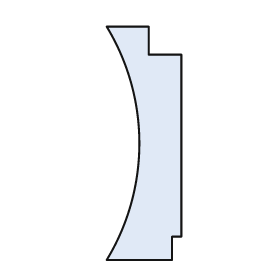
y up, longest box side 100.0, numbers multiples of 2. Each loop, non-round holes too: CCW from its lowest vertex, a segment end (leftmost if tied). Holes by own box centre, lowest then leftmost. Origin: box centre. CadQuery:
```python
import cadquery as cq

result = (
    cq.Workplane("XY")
    .moveTo(-16.0, -50.0)
    .lineTo(12.0, -50.0)
    .lineTo(12.0, -40.0)
    .lineTo(16.0, -40.0)
    .lineTo(16.0, 38.0)
    .lineTo(2.0, 38.0)
    .lineTo(2.0, 50.0)
    .lineTo(-16.0, 50.0)
    .threePointArc((-2.0, 0.0), (-16.0, -50.0))
    .close()
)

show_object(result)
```